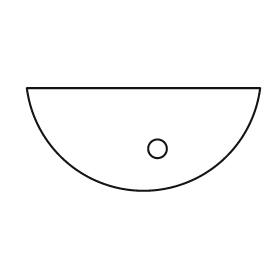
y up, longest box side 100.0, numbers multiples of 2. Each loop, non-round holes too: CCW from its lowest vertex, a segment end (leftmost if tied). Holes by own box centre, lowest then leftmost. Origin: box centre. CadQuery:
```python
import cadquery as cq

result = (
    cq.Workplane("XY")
    .moveTo(-50.0, 22.0)
    .threePointArc((0.0, -22.0), (50.0, 22.0))
    .close()
    .moveTo(6.0, -4.0)
    .circle(4.0)
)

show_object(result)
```